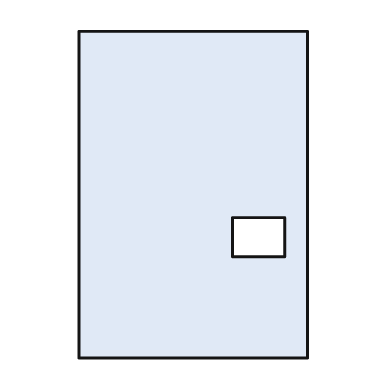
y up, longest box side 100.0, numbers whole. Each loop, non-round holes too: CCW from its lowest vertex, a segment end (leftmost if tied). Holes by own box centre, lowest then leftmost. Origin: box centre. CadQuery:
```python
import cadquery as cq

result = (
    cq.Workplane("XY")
    .moveTo(-35.0, -50.0)
    .lineTo(35.0, -50.0)
    .lineTo(35.0, 50.0)
    .lineTo(-35.0, 50.0)
    .close()
    .moveTo(12.0, -19.0)
    .lineTo(28.0, -19.0)
    .lineTo(28.0, -7.0)
    .lineTo(12.0, -7.0)
    .close()
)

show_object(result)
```